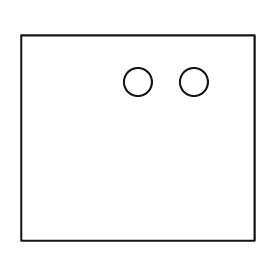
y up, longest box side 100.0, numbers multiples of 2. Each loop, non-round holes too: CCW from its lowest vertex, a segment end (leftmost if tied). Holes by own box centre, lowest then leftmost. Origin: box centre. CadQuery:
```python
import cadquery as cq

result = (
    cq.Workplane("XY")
    .moveTo(-50.0, -44.0)
    .lineTo(50.0, -44.0)
    .lineTo(50.0, 44.0)
    .lineTo(-50.0, 44.0)
    .close()
    .moveTo(0.0, 24.0)
    .circle(6.0)
    .moveTo(24.0, 24.0)
    .circle(6.0)
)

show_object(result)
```